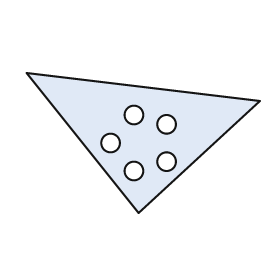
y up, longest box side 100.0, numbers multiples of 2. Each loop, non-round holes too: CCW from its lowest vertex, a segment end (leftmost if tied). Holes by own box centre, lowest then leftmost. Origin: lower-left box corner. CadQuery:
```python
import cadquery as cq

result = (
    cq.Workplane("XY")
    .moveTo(48.0, 0.0)
    .lineTo(100.0, 48.0)
    .lineTo(0.0, 60.0)
    .close()
    .moveTo(46.0, 18.0)
    .circle(4.0)
    .moveTo(60.0, 22.0)
    .circle(4.0)
    .moveTo(36.0, 30.0)
    .circle(4.0)
    .moveTo(60.0, 38.0)
    .circle(4.0)
    .moveTo(46.0, 42.0)
    .circle(4.0)
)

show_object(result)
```